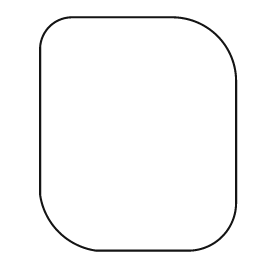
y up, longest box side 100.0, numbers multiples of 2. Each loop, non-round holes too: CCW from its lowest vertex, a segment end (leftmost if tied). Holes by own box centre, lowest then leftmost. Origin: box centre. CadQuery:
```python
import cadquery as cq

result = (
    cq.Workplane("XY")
    .moveTo(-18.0, -50.0)
    .lineTo(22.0, -50.0)
    .threePointArc((36.0, -44.0), (42.0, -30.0))
    .lineTo(42.0, 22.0)
    .threePointArc((34.0, 42.0), (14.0, 50.0))
    .lineTo(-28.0, 50.0)
    .threePointArc((-38.0, 46.0), (-42.0, 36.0))
    .lineTo(-42.0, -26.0)
    .threePointArc((-34.0, -42.0), (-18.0, -50.0))
    .close()
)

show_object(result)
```